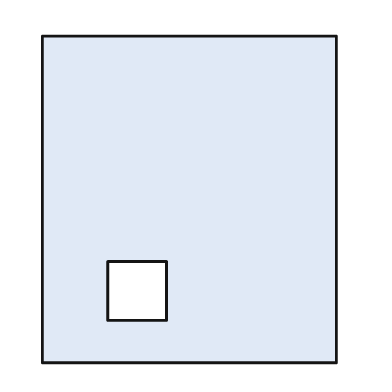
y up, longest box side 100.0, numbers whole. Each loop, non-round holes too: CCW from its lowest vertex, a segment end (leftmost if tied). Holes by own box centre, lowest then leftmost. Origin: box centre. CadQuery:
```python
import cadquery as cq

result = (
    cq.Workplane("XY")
    .moveTo(-45.0, -50.0)
    .lineTo(45.0, -50.0)
    .lineTo(45.0, 50.0)
    .lineTo(-45.0, 50.0)
    .close()
    .moveTo(-25.0, -37.0)
    .lineTo(-7.0, -37.0)
    .lineTo(-7.0, -19.0)
    .lineTo(-25.0, -19.0)
    .close()
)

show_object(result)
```